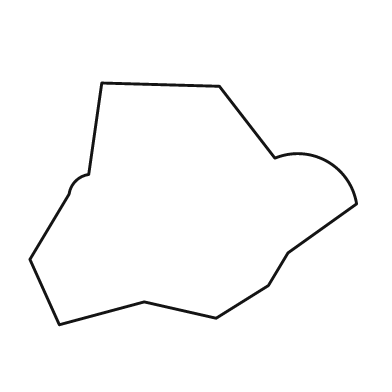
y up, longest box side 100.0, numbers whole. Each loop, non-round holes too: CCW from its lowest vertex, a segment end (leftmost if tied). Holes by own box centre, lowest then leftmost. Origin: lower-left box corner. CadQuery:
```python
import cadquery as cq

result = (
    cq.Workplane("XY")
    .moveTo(9.0, 0.0)
    .lineTo(35.0, 7.0)
    .lineTo(57.0, 2.0)
    .lineTo(73.0, 12.0)
    .lineTo(79.0, 22.0)
    .lineTo(100.0, 37.0)
    .threePointArc((91.0, 50.0), (75.0, 51.0))
    .lineTo(58.0, 73.0)
    .lineTo(22.0, 74.0)
    .lineTo(18.0, 46.0)
    .threePointArc((14.0, 44.0), (12.0, 40.0))
    .lineTo(0.0, 20.0)
    .close()
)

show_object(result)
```